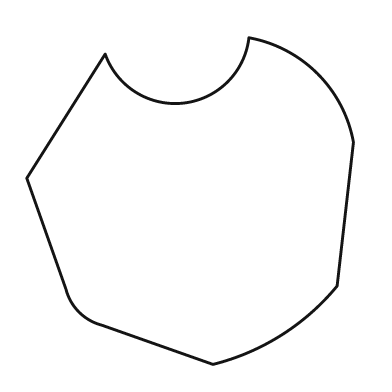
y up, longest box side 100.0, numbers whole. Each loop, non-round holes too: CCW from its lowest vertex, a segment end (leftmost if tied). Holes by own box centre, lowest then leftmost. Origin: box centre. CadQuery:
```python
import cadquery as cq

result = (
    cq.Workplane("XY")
    .moveTo(7.0, -50.0)
    .threePointArc((28.0, -41.0), (45.0, -26.0))
    .lineTo(50.0, 18.0)
    .threePointArc((39.0, 39.0), (18.0, 50.0))
    .threePointArc((-2.0, 30.0), (-26.0, 45.0))
    .lineTo(-50.0, 7.0)
    .lineTo(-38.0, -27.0)
    .threePointArc((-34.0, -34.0), (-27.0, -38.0))
    .close()
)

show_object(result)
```